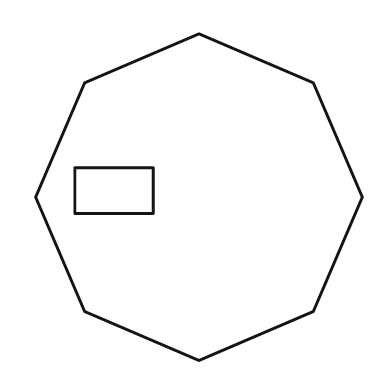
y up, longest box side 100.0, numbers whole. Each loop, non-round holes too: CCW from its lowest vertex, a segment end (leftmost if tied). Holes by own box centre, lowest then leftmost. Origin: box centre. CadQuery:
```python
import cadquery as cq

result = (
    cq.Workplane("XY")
    .moveTo(0.0, -50.0)
    .lineTo(35.0, -35.0)
    .lineTo(50.0, 0.0)
    .lineTo(35.0, 35.0)
    .lineTo(0.0, 50.0)
    .lineTo(-35.0, 35.0)
    .lineTo(-50.0, 0.0)
    .lineTo(-35.0, -35.0)
    .close()
    .moveTo(-38.0, -5.0)
    .lineTo(-14.0, -5.0)
    .lineTo(-14.0, 9.0)
    .lineTo(-38.0, 9.0)
    .close()
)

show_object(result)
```